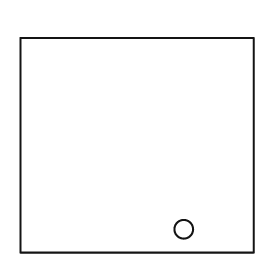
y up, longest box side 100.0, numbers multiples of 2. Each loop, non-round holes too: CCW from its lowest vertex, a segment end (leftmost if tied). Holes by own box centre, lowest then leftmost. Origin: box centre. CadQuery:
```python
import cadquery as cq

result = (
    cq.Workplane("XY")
    .moveTo(-50.0, -46.0)
    .lineTo(50.0, -46.0)
    .lineTo(50.0, 46.0)
    .lineTo(-50.0, 46.0)
    .close()
    .moveTo(20.0, -36.0)
    .circle(4.0)
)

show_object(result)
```